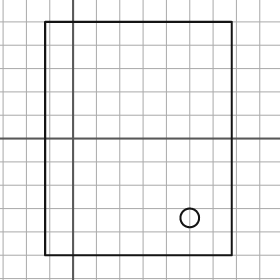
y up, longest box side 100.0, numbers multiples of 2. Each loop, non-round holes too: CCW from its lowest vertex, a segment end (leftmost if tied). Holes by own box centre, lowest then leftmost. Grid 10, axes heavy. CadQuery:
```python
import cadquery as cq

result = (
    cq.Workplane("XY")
    .moveTo(-12.0, -50.0)
    .lineTo(68.0, -50.0)
    .lineTo(68.0, 50.0)
    .lineTo(-12.0, 50.0)
    .close()
    .moveTo(50.0, -34.0)
    .circle(4.0)
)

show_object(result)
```